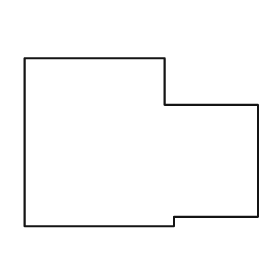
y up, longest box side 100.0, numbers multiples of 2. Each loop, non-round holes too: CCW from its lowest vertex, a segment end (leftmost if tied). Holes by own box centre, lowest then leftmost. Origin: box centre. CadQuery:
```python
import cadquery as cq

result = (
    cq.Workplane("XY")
    .moveTo(-50.0, -36.0)
    .lineTo(14.0, -36.0)
    .lineTo(14.0, -32.0)
    .lineTo(50.0, -32.0)
    .lineTo(50.0, 16.0)
    .lineTo(10.0, 16.0)
    .lineTo(10.0, 36.0)
    .lineTo(-50.0, 36.0)
    .close()
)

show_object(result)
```